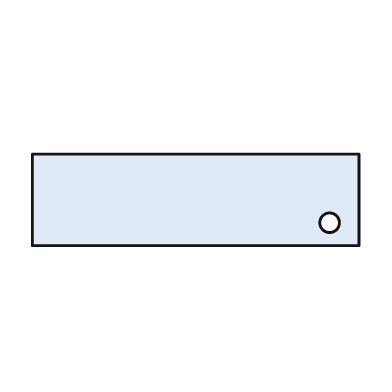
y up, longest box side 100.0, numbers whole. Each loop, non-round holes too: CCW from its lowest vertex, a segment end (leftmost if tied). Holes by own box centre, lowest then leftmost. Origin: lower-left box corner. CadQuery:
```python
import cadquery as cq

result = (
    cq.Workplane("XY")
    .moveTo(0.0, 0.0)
    .lineTo(100.0, 0.0)
    .lineTo(100.0, 28.0)
    .lineTo(0.0, 28.0)
    .close()
    .moveTo(91.0, 7.0)
    .circle(3.0)
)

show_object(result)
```